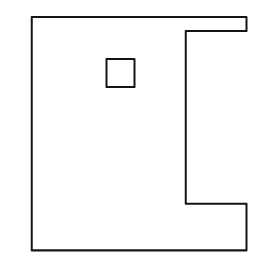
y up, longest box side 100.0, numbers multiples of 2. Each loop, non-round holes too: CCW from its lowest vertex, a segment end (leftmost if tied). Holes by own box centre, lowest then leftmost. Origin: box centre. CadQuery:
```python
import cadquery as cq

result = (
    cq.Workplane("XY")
    .moveTo(-46.0, -50.0)
    .lineTo(46.0, -50.0)
    .lineTo(46.0, -30.0)
    .lineTo(20.0, -30.0)
    .lineTo(20.0, 44.0)
    .lineTo(46.0, 44.0)
    .lineTo(46.0, 50.0)
    .lineTo(-46.0, 50.0)
    .close()
    .moveTo(-14.0, 20.0)
    .lineTo(-2.0, 20.0)
    .lineTo(-2.0, 32.0)
    .lineTo(-14.0, 32.0)
    .close()
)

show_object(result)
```